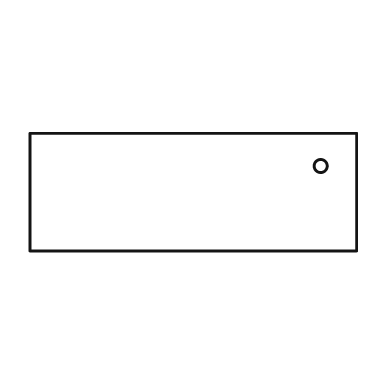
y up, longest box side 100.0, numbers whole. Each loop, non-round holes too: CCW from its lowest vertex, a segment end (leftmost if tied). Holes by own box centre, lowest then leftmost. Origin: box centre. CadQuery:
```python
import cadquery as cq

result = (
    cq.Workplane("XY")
    .moveTo(-50.0, -18.0)
    .lineTo(50.0, -18.0)
    .lineTo(50.0, 18.0)
    .lineTo(-50.0, 18.0)
    .close()
    .moveTo(39.0, 8.0)
    .circle(2.0)
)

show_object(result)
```